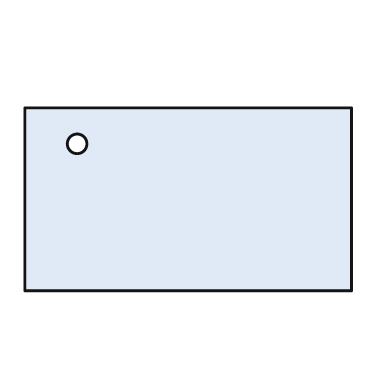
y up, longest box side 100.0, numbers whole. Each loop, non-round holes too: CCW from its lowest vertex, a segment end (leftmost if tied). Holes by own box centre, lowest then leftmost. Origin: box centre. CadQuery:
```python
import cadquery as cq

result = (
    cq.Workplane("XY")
    .moveTo(-50.0, -28.0)
    .lineTo(50.0, -28.0)
    .lineTo(50.0, 28.0)
    .lineTo(-50.0, 28.0)
    .close()
    .moveTo(-34.0, 17.0)
    .circle(3.0)
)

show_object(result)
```